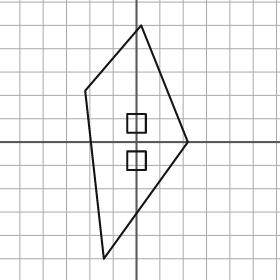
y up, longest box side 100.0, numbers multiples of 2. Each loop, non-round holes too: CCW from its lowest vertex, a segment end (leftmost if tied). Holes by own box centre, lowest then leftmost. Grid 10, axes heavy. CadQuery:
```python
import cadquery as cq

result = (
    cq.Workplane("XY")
    .moveTo(-14.0, -50.0)
    .lineTo(22.0, 0.0)
    .lineTo(2.0, 50.0)
    .lineTo(-22.0, 22.0)
    .close()
    .moveTo(-4.0, -12.0)
    .lineTo(4.0, -12.0)
    .lineTo(4.0, -4.0)
    .lineTo(-4.0, -4.0)
    .close()
    .moveTo(-4.0, 4.0)
    .lineTo(4.0, 4.0)
    .lineTo(4.0, 12.0)
    .lineTo(-4.0, 12.0)
    .close()
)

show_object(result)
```